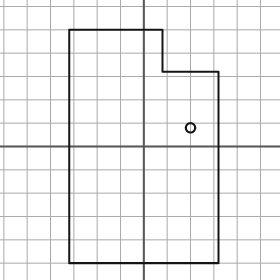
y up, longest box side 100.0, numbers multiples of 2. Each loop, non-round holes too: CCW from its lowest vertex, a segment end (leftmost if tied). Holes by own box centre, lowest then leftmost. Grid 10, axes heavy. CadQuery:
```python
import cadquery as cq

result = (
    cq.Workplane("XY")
    .moveTo(-32.0, -50.0)
    .lineTo(32.0, -50.0)
    .lineTo(32.0, 32.0)
    .lineTo(8.0, 32.0)
    .lineTo(8.0, 50.0)
    .lineTo(-32.0, 50.0)
    .close()
    .moveTo(20.0, 8.0)
    .circle(2.0)
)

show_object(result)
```